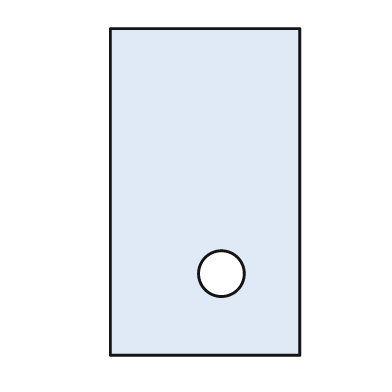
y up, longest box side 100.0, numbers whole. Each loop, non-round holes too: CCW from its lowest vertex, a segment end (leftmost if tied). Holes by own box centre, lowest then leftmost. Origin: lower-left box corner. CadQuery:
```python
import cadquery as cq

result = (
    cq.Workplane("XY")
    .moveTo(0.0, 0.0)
    .lineTo(58.0, 0.0)
    .lineTo(58.0, 100.0)
    .lineTo(0.0, 100.0)
    .close()
    .moveTo(34.0, 25.0)
    .circle(7.0)
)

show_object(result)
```